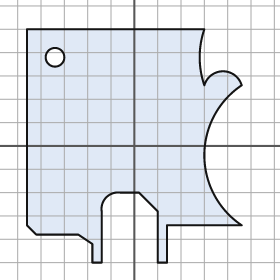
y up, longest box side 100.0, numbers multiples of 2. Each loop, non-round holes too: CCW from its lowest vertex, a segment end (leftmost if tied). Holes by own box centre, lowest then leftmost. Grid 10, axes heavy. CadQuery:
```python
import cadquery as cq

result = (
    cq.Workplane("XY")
    .moveTo(-18.0, -50.0)
    .lineTo(-14.0, -50.0)
    .lineTo(-14.0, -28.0)
    .threePointArc((-12.0, -22.0), (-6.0, -20.0))
    .lineTo(2.0, -20.0)
    .lineTo(10.0, -28.0)
    .lineTo(10.0, -50.0)
    .lineTo(14.0, -50.0)
    .lineTo(14.0, -34.0)
    .lineTo(46.0, -34.0)
    .threePointArc((30.0, -4.0), (46.0, 26.0))
    .threePointArc((38.0, 32.0), (30.0, 26.0))
    .threePointArc((28.0, 38.0), (30.0, 50.0))
    .lineTo(-46.0, 50.0)
    .lineTo(-46.0, -34.0)
    .lineTo(-42.0, -38.0)
    .lineTo(-24.0, -38.0)
    .lineTo(-18.0, -42.0)
    .close()
    .moveTo(-34.0, 38.0)
    .circle(4.0)
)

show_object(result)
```